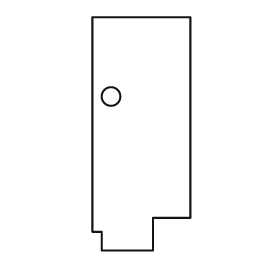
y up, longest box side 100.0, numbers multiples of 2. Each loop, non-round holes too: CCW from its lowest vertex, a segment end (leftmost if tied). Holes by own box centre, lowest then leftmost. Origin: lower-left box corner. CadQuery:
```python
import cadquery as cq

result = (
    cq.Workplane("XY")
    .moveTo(4.0, 0.0)
    .lineTo(26.0, 0.0)
    .lineTo(26.0, 14.0)
    .lineTo(42.0, 14.0)
    .lineTo(42.0, 100.0)
    .lineTo(0.0, 100.0)
    .lineTo(0.0, 8.0)
    .lineTo(4.0, 8.0)
    .close()
    .moveTo(8.0, 66.0)
    .circle(4.0)
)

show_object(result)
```